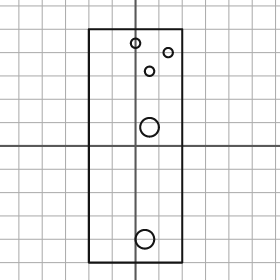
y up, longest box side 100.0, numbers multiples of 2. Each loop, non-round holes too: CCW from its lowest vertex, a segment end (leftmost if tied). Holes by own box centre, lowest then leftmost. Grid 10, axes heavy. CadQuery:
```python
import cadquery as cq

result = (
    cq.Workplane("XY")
    .moveTo(-20.0, -50.0)
    .lineTo(20.0, -50.0)
    .lineTo(20.0, 50.0)
    .lineTo(-20.0, 50.0)
    .close()
    .moveTo(4.0, -40.0)
    .circle(4.0)
    .moveTo(6.0, 8.0)
    .circle(4.0)
    .moveTo(6.0, 32.0)
    .circle(2.0)
    .moveTo(14.0, 40.0)
    .circle(2.0)
    .moveTo(0.0, 44.0)
    .circle(2.0)
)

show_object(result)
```